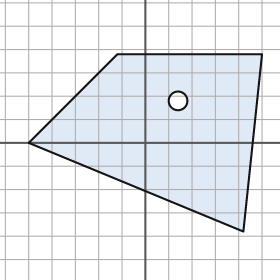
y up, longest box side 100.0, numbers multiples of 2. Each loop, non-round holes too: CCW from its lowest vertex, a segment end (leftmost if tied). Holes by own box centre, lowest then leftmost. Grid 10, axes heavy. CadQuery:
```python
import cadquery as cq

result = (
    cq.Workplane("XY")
    .moveTo(42.0, -38.0)
    .lineTo(50.0, 38.0)
    .lineTo(-12.0, 38.0)
    .lineTo(-50.0, 0.0)
    .close()
    .moveTo(14.0, 18.0)
    .circle(4.0)
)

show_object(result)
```